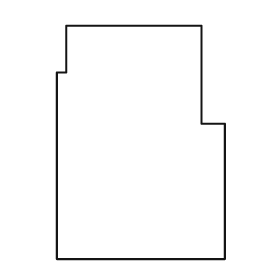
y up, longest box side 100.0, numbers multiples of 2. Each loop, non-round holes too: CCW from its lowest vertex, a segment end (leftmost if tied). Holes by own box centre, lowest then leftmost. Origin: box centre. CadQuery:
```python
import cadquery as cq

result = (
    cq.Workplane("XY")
    .moveTo(-36.0, -50.0)
    .lineTo(36.0, -50.0)
    .lineTo(36.0, 8.0)
    .lineTo(26.0, 8.0)
    .lineTo(26.0, 50.0)
    .lineTo(-32.0, 50.0)
    .lineTo(-32.0, 30.0)
    .lineTo(-36.0, 30.0)
    .close()
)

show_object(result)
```